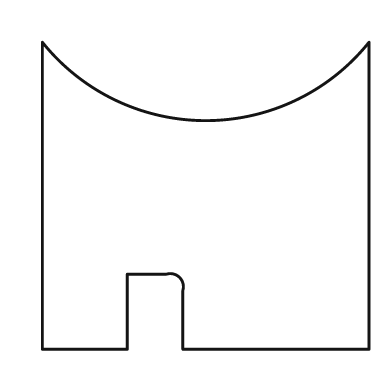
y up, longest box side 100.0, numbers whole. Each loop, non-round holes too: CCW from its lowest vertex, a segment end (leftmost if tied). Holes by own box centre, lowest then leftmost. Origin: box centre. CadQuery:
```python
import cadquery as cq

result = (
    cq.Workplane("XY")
    .moveTo(-50.0, -47.0)
    .lineTo(-24.0, -47.0)
    .lineTo(-24.0, -24.0)
    .lineTo(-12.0, -24.0)
    .threePointArc((-8.0, -25.0), (-7.0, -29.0))
    .lineTo(-7.0, -47.0)
    .lineTo(50.0, -47.0)
    .lineTo(50.0, 47.0)
    .threePointArc((0.0, 23.0), (-50.0, 47.0))
    .close()
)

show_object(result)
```